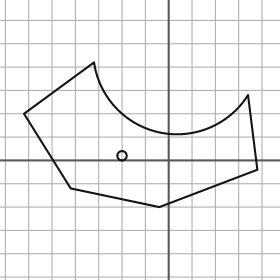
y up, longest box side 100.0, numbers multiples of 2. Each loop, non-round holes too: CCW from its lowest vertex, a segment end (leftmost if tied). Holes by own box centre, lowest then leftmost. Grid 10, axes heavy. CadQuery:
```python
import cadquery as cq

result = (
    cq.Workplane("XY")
    .moveTo(-4.0, -20.0)
    .lineTo(38.0, -4.0)
    .lineTo(34.0, 28.0)
    .threePointArc((-4.0, 12.0), (-32.0, 42.0))
    .lineTo(-62.0, 20.0)
    .lineTo(-42.0, -12.0)
    .close()
    .moveTo(-20.0, 2.0)
    .circle(2.0)
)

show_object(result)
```